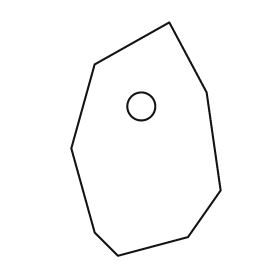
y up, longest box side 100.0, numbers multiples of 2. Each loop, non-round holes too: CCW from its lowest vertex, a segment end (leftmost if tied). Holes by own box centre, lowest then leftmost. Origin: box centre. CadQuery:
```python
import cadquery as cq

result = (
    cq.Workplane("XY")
    .moveTo(-12.0, -50.0)
    .lineTo(18.0, -42.0)
    .lineTo(32.0, -22.0)
    .lineTo(26.0, 20.0)
    .lineTo(10.0, 50.0)
    .lineTo(-22.0, 32.0)
    .lineTo(-32.0, -4.0)
    .lineTo(-22.0, -40.0)
    .close()
    .moveTo(-2.0, 14.0)
    .circle(6.0)
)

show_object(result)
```